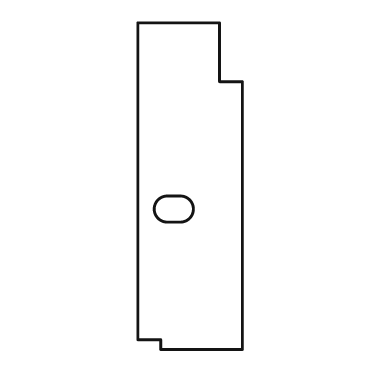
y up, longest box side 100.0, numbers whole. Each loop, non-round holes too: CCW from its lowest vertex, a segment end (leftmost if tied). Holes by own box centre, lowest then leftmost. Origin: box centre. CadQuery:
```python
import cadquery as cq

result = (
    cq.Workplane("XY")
    .moveTo(-9.0, -50.0)
    .lineTo(16.0, -50.0)
    .lineTo(16.0, 32.0)
    .lineTo(9.0, 32.0)
    .lineTo(9.0, 50.0)
    .lineTo(-16.0, 50.0)
    .lineTo(-16.0, -47.0)
    .lineTo(-9.0, -47.0)
    .close()
    .moveTo(-7.0, -11.0)
    .lineTo(-3.0, -11.0)
    .threePointArc((1.0, -7.0), (-3.0, -3.0))
    .lineTo(-7.0, -3.0)
    .threePointArc((-11.0, -7.0), (-7.0, -11.0))
    .close()
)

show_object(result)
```